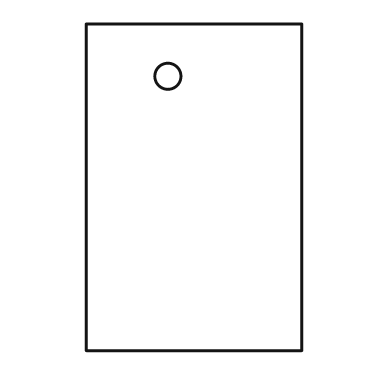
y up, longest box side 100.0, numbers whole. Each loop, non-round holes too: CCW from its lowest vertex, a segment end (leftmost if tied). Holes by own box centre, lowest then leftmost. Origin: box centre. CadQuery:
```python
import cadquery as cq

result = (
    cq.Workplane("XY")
    .moveTo(-33.0, -50.0)
    .lineTo(33.0, -50.0)
    .lineTo(33.0, 50.0)
    .lineTo(-33.0, 50.0)
    .close()
    .moveTo(-8.0, 34.0)
    .circle(4.0)
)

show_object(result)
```